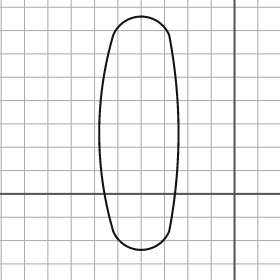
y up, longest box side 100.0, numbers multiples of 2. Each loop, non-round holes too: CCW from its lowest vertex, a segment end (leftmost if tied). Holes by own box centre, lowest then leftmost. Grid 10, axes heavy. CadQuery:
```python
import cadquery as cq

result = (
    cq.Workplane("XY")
    .moveTo(-52.0, -16.0)
    .threePointArc((-40.0, -24.0), (-28.0, -16.0))
    .threePointArc((-24.0, 26.0), (-28.0, 68.0))
    .threePointArc((-40.0, 76.0), (-52.0, 68.0))
    .threePointArc((-58.0, 26.0), (-52.0, -16.0))
    .close()
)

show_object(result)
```